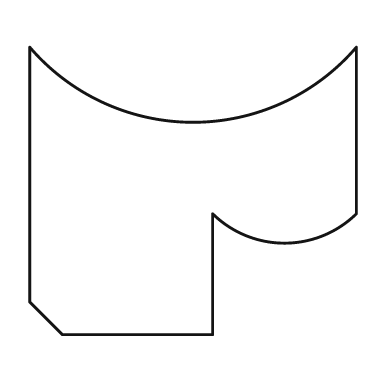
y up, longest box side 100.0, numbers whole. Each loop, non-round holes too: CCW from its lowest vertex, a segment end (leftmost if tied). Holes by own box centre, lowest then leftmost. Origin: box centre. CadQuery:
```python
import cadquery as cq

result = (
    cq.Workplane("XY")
    .moveTo(-40.0, -44.0)
    .lineTo(6.0, -44.0)
    .lineTo(6.0, -7.0)
    .threePointArc((28.0, -16.0), (50.0, -7.0))
    .lineTo(50.0, 44.0)
    .threePointArc((0.0, 21.0), (-50.0, 44.0))
    .lineTo(-50.0, -34.0)
    .close()
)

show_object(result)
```